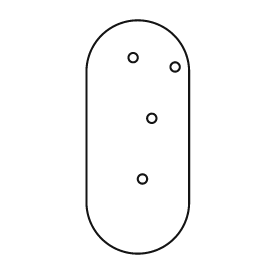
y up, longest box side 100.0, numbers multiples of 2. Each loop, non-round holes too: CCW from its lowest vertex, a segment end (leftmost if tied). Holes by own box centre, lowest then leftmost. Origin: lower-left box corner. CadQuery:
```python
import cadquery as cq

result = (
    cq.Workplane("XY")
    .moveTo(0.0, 22.0)
    .threePointArc((22.0, 0.0), (44.0, 22.0))
    .lineTo(44.0, 78.0)
    .threePointArc((22.0, 100.0), (0.0, 78.0))
    .close()
    .moveTo(24.0, 32.0)
    .circle(2.0)
    .moveTo(28.0, 58.0)
    .circle(2.0)
    .moveTo(38.0, 80.0)
    .circle(2.0)
    .moveTo(20.0, 84.0)
    .circle(2.0)
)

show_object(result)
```